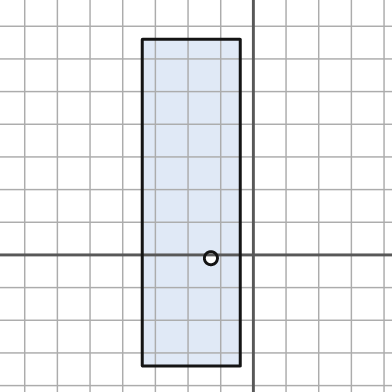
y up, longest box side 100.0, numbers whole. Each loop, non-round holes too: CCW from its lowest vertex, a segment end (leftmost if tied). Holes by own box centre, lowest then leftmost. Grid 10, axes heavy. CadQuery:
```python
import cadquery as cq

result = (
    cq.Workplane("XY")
    .moveTo(-34.0, -34.0)
    .lineTo(-4.0, -34.0)
    .lineTo(-4.0, 66.0)
    .lineTo(-34.0, 66.0)
    .close()
    .moveTo(-13.0, -1.0)
    .circle(2.0)
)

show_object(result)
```